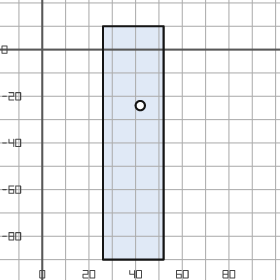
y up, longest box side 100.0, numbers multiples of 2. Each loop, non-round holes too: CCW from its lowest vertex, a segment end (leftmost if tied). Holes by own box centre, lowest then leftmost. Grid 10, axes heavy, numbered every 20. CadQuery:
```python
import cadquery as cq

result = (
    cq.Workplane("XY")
    .moveTo(26.0, -90.0)
    .lineTo(52.0, -90.0)
    .lineTo(52.0, 10.0)
    .lineTo(26.0, 10.0)
    .close()
    .moveTo(42.0, -24.0)
    .circle(2.0)
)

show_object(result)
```